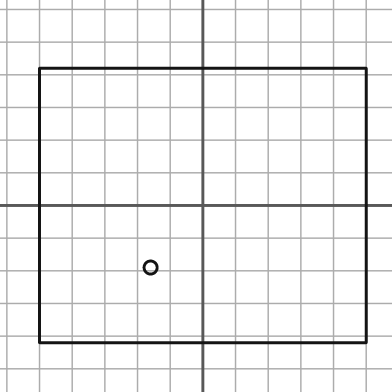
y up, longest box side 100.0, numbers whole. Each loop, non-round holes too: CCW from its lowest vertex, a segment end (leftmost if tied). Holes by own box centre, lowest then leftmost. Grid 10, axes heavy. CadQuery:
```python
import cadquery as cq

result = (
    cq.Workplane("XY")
    .moveTo(-50.0, -42.0)
    .lineTo(50.0, -42.0)
    .lineTo(50.0, 42.0)
    .lineTo(-50.0, 42.0)
    .close()
    .moveTo(-16.0, -19.0)
    .circle(2.0)
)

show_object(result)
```